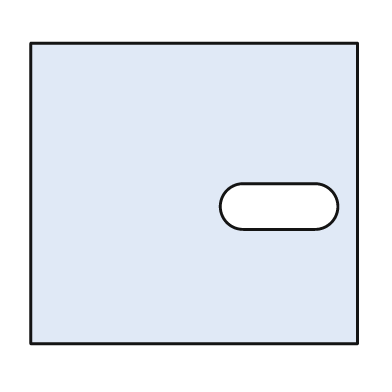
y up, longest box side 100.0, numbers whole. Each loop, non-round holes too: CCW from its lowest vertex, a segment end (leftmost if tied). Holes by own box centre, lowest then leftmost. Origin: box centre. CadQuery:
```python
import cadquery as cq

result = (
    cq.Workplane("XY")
    .moveTo(-50.0, -46.0)
    .lineTo(50.0, -46.0)
    .lineTo(50.0, 46.0)
    .lineTo(-50.0, 46.0)
    .close()
    .moveTo(15.0, -11.0)
    .lineTo(37.0, -11.0)
    .threePointArc((44.0, -4.0), (37.0, 3.0))
    .lineTo(15.0, 3.0)
    .threePointArc((8.0, -4.0), (15.0, -11.0))
    .close()
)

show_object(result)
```